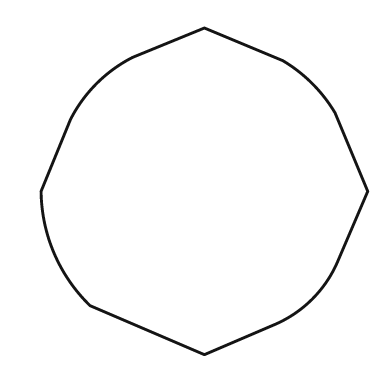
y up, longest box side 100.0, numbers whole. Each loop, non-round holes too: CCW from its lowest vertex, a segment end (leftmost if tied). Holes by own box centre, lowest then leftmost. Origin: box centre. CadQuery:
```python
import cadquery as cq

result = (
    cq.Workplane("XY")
    .moveTo(0.0, -50.0)
    .lineTo(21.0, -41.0)
    .threePointArc((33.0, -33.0), (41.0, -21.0))
    .lineTo(50.0, 0.0)
    .lineTo(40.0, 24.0)
    .threePointArc((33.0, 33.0), (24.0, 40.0))
    .lineTo(0.0, 50.0)
    .lineTo(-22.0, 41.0)
    .threePointArc((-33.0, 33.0), (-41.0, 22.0))
    .lineTo(-50.0, 0.0)
    .threePointArc((-46.0, -19.0), (-35.0, -35.0))
    .close()
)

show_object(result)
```